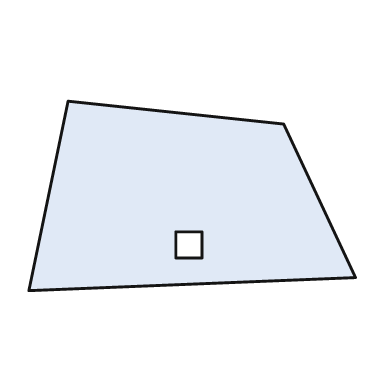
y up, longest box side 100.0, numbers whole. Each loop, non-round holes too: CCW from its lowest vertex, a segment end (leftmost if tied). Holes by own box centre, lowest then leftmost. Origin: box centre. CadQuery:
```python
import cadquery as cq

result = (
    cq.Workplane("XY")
    .moveTo(-50.0, -29.0)
    .lineTo(50.0, -25.0)
    .lineTo(28.0, 22.0)
    .lineTo(-38.0, 29.0)
    .close()
    .moveTo(-5.0, -19.0)
    .lineTo(3.0, -19.0)
    .lineTo(3.0, -11.0)
    .lineTo(-5.0, -11.0)
    .close()
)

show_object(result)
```